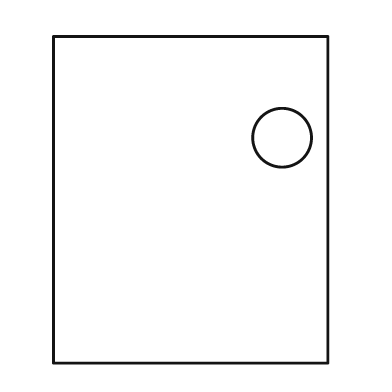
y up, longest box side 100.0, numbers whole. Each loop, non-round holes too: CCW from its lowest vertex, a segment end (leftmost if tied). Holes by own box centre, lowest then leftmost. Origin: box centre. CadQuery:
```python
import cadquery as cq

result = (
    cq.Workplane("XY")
    .moveTo(-42.0, -50.0)
    .lineTo(42.0, -50.0)
    .lineTo(42.0, 50.0)
    .lineTo(-42.0, 50.0)
    .close()
    .moveTo(28.0, 19.0)
    .circle(9.0)
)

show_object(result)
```